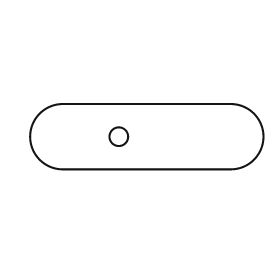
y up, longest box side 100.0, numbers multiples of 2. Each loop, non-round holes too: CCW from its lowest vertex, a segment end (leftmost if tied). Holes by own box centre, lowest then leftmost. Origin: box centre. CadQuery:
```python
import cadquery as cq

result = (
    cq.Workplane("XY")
    .moveTo(-36.0, -14.0)
    .lineTo(36.0, -14.0)
    .threePointArc((50.0, 0.0), (36.0, 14.0))
    .lineTo(-36.0, 14.0)
    .threePointArc((-50.0, 0.0), (-36.0, -14.0))
    .close()
    .moveTo(-12.0, 0.0)
    .circle(4.0)
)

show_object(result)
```